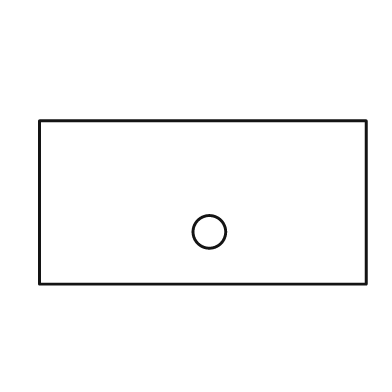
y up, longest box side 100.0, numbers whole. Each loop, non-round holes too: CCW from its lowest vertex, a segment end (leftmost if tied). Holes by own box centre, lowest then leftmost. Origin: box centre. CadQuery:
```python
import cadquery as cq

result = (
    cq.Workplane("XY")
    .moveTo(-50.0, -25.0)
    .lineTo(50.0, -25.0)
    .lineTo(50.0, 25.0)
    .lineTo(-50.0, 25.0)
    .close()
    .moveTo(2.0, -9.0)
    .circle(5.0)
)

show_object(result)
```